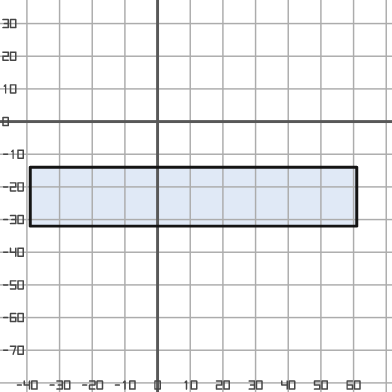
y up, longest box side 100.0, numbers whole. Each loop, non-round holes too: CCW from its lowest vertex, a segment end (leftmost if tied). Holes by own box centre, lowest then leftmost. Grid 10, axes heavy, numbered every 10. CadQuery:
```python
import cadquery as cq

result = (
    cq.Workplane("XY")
    .moveTo(-39.0, -32.0)
    .lineTo(61.0, -32.0)
    .lineTo(61.0, -14.0)
    .lineTo(-39.0, -14.0)
    .close()
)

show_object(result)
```